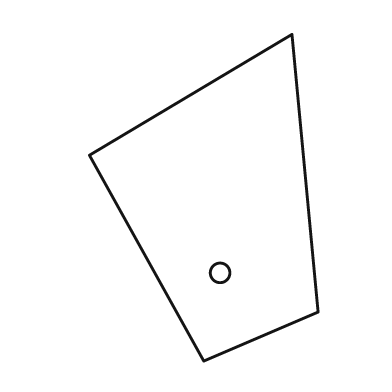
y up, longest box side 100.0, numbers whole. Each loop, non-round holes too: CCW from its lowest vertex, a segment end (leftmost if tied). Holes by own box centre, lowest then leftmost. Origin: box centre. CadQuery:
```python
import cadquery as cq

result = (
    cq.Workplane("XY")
    .moveTo(0.0, -50.0)
    .lineTo(35.0, -35.0)
    .lineTo(27.0, 50.0)
    .lineTo(-35.0, 13.0)
    .close()
    .moveTo(5.0, -23.0)
    .circle(3.0)
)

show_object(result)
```